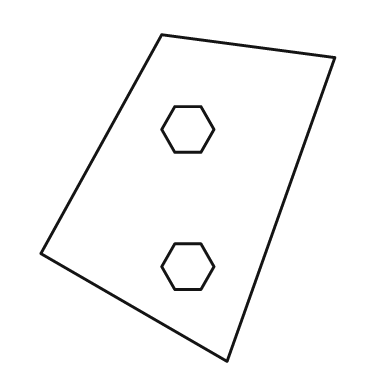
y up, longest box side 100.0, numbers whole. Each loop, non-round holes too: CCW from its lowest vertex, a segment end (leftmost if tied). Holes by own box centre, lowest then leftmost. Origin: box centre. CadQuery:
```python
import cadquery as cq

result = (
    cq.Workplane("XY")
    .moveTo(12.0, -50.0)
    .lineTo(45.0, 43.0)
    .lineTo(-8.0, 50.0)
    .lineTo(-45.0, -17.0)
    .close()
    .moveTo(-4.0, -28.0)
    .lineTo(4.0, -28.0)
    .lineTo(8.0, -21.0)
    .lineTo(4.0, -14.0)
    .lineTo(-4.0, -14.0)
    .lineTo(-8.0, -21.0)
    .close()
    .moveTo(-4.0, 14.0)
    .lineTo(4.0, 14.0)
    .lineTo(8.0, 21.0)
    .lineTo(4.0, 28.0)
    .lineTo(-4.0, 28.0)
    .lineTo(-8.0, 21.0)
    .close()
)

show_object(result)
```